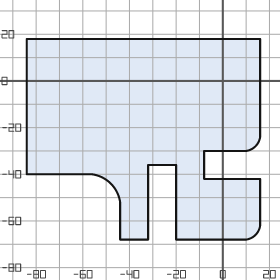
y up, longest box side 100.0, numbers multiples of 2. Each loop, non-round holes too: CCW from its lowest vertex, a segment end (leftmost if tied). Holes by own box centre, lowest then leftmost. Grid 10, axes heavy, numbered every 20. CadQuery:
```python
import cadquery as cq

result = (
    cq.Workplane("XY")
    .moveTo(-44.0, -68.0)
    .lineTo(-32.0, -68.0)
    .lineTo(-32.0, -36.0)
    .lineTo(-20.0, -36.0)
    .lineTo(-20.0, -68.0)
    .lineTo(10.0, -68.0)
    .threePointArc((14.0, -66.0), (16.0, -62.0))
    .lineTo(16.0, -42.0)
    .lineTo(-8.0, -42.0)
    .lineTo(-8.0, -30.0)
    .lineTo(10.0, -30.0)
    .threePointArc((14.0, -28.0), (16.0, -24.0))
    .lineTo(16.0, 18.0)
    .lineTo(-84.0, 18.0)
    .lineTo(-84.0, -40.0)
    .lineTo(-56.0, -40.0)
    .threePointArc((-48.0, -44.0), (-44.0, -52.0))
    .close()
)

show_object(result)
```